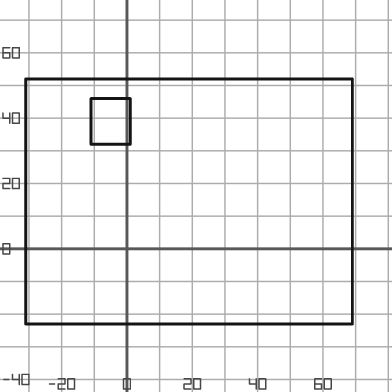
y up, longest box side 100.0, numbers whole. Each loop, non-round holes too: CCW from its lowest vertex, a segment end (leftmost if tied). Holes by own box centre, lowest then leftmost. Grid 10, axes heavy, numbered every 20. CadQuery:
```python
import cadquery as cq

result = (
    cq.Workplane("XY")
    .moveTo(-31.0, -23.0)
    .lineTo(69.0, -23.0)
    .lineTo(69.0, 52.0)
    .lineTo(-31.0, 52.0)
    .close()
    .moveTo(-11.0, 32.0)
    .lineTo(1.0, 32.0)
    .lineTo(1.0, 46.0)
    .lineTo(-11.0, 46.0)
    .close()
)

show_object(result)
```